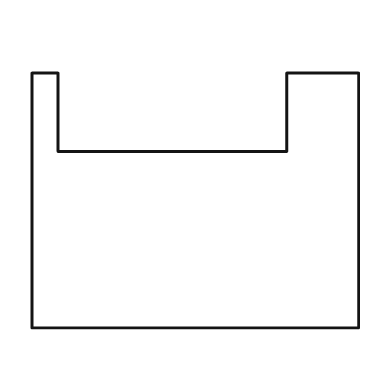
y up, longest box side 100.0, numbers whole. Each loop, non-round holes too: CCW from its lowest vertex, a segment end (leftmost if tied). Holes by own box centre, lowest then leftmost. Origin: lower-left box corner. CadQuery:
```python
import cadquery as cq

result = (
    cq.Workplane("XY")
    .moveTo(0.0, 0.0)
    .lineTo(100.0, 0.0)
    .lineTo(100.0, 78.0)
    .lineTo(78.0, 78.0)
    .lineTo(78.0, 54.0)
    .lineTo(8.0, 54.0)
    .lineTo(8.0, 78.0)
    .lineTo(0.0, 78.0)
    .close()
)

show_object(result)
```